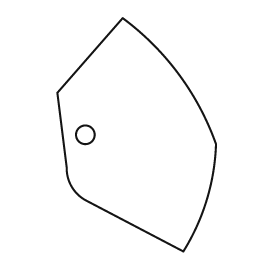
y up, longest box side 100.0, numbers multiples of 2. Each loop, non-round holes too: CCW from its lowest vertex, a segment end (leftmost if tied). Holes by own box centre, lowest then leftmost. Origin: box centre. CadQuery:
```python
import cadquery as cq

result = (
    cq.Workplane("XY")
    .moveTo(20.0, -50.0)
    .threePointArc((30.0, -28.0), (34.0, -4.0))
    .threePointArc((18.0, 26.0), (-6.0, 50.0))
    .lineTo(-34.0, 18.0)
    .lineTo(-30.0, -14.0)
    .threePointArc((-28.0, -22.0), (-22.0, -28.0))
    .close()
    .moveTo(-22.0, 0.0)
    .circle(4.0)
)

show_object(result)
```